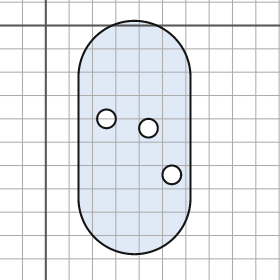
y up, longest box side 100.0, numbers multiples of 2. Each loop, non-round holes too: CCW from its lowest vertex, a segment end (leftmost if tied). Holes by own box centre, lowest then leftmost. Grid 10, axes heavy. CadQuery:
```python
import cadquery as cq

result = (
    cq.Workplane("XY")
    .moveTo(14.0, -74.0)
    .threePointArc((38.0, -98.0), (62.0, -74.0))
    .lineTo(62.0, -22.0)
    .threePointArc((38.0, 2.0), (14.0, -22.0))
    .close()
    .moveTo(54.0, -64.0)
    .circle(4.0)
    .moveTo(44.0, -44.0)
    .circle(4.0)
    .moveTo(26.0, -40.0)
    .circle(4.0)
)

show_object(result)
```